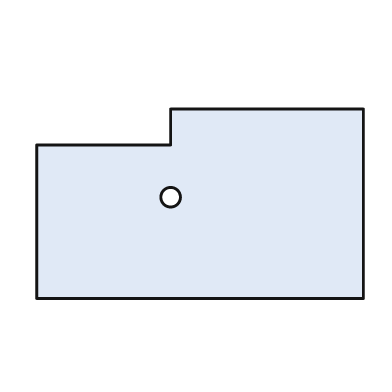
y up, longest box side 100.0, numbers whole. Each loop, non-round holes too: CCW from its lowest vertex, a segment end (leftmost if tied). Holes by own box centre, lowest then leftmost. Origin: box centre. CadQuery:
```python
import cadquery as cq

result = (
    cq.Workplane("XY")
    .moveTo(-50.0, -29.0)
    .lineTo(50.0, -29.0)
    .lineTo(50.0, 29.0)
    .lineTo(-9.0, 29.0)
    .lineTo(-9.0, 18.0)
    .lineTo(-50.0, 18.0)
    .close()
    .moveTo(-9.0, 2.0)
    .circle(3.0)
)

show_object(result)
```